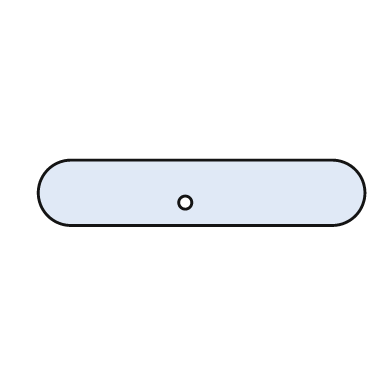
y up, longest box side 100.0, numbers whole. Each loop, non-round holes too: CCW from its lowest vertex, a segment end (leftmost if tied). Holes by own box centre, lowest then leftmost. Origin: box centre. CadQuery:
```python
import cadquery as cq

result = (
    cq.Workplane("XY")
    .moveTo(-40.0, -10.0)
    .lineTo(40.0, -10.0)
    .threePointArc((50.0, 0.0), (40.0, 10.0))
    .lineTo(-40.0, 10.0)
    .threePointArc((-50.0, 0.0), (-40.0, -10.0))
    .close()
    .moveTo(-5.0, -3.0)
    .circle(2.0)
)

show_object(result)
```